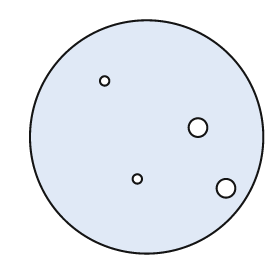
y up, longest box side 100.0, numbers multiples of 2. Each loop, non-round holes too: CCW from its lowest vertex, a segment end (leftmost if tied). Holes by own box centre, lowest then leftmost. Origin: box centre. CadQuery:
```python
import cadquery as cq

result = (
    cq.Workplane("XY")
    .moveTo(0.0, 0.0)
    .circle(50.0)
    .moveTo(34.0, -22.0)
    .circle(4.0)
    .moveTo(-4.0, -18.0)
    .circle(2.0)
    .moveTo(22.0, 4.0)
    .circle(4.0)
    .moveTo(-18.0, 24.0)
    .circle(2.0)
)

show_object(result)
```